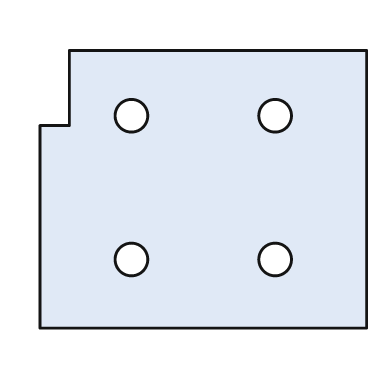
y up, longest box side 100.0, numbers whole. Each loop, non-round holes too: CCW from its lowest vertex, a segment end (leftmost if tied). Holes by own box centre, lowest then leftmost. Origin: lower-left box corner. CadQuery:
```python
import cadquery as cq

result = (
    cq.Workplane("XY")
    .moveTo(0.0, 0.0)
    .lineTo(100.0, 0.0)
    .lineTo(100.0, 85.0)
    .lineTo(9.0, 85.0)
    .lineTo(9.0, 62.0)
    .lineTo(0.0, 62.0)
    .close()
    .moveTo(28.0, 21.0)
    .circle(5.0)
    .moveTo(72.0, 21.0)
    .circle(5.0)
    .moveTo(28.0, 65.0)
    .circle(5.0)
    .moveTo(72.0, 65.0)
    .circle(5.0)
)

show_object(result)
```